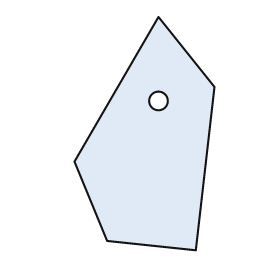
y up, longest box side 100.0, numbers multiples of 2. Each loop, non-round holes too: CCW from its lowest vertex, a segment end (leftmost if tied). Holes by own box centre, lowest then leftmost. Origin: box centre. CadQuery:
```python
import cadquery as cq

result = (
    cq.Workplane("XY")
    .moveTo(22.0, -50.0)
    .lineTo(30.0, 20.0)
    .lineTo(6.0, 50.0)
    .lineTo(-30.0, -12.0)
    .lineTo(-16.0, -46.0)
    .close()
    .moveTo(6.0, 14.0)
    .circle(4.0)
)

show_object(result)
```